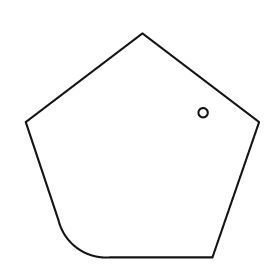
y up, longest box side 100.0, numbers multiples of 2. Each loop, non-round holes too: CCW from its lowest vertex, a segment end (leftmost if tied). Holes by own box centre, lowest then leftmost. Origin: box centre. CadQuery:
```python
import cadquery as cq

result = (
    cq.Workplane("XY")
    .moveTo(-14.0, -48.0)
    .lineTo(30.0, -48.0)
    .lineTo(50.0, 10.0)
    .lineTo(0.0, 48.0)
    .lineTo(-50.0, 10.0)
    .lineTo(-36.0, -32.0)
    .threePointArc((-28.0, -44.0), (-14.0, -48.0))
    .close()
    .moveTo(26.0, 14.0)
    .circle(2.0)
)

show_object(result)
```